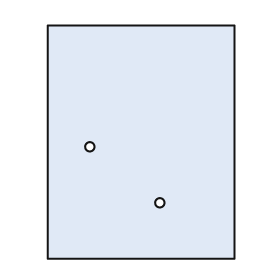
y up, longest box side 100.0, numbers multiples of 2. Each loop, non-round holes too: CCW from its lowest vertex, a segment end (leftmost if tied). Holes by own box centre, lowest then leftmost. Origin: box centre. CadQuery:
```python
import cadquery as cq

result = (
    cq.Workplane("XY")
    .moveTo(-40.0, -50.0)
    .lineTo(40.0, -50.0)
    .lineTo(40.0, 50.0)
    .lineTo(-40.0, 50.0)
    .close()
    .moveTo(8.0, -26.0)
    .circle(2.0)
    .moveTo(-22.0, -2.0)
    .circle(2.0)
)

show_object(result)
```